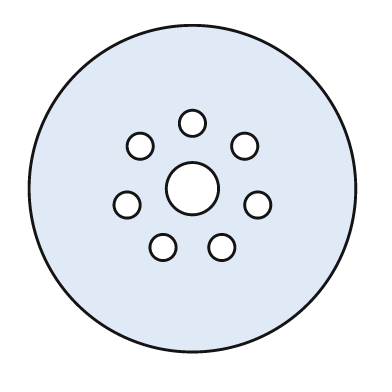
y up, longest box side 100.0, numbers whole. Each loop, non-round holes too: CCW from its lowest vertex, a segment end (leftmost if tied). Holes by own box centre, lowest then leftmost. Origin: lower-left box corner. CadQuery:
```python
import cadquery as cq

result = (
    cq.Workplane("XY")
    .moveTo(50.0, 50.0)
    .circle(50.0)
    .moveTo(41.0, 32.0)
    .circle(4.0)
    .moveTo(59.0, 32.0)
    .circle(4.0)
    .moveTo(30.0, 45.0)
    .circle(4.0)
    .moveTo(70.0, 45.0)
    .circle(4.0)
    .moveTo(50.0, 50.0)
    .circle(8.0)
    .moveTo(34.0, 63.0)
    .circle(4.0)
    .moveTo(66.0, 63.0)
    .circle(4.0)
    .moveTo(50.0, 70.0)
    .circle(4.0)
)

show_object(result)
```